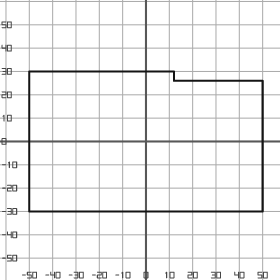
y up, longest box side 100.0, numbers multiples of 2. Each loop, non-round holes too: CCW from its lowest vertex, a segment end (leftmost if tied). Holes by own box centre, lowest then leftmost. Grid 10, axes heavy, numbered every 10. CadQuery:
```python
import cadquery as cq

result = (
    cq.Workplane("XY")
    .moveTo(-50.0, -30.0)
    .lineTo(50.0, -30.0)
    .lineTo(50.0, 26.0)
    .lineTo(12.0, 26.0)
    .lineTo(12.0, 30.0)
    .lineTo(-50.0, 30.0)
    .close()
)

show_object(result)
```